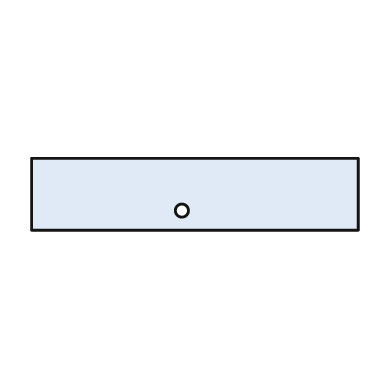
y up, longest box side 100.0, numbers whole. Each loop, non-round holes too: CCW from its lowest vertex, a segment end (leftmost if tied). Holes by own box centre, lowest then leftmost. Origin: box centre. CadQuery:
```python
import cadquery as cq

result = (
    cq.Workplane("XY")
    .moveTo(-50.0, -11.0)
    .lineTo(50.0, -11.0)
    .lineTo(50.0, 11.0)
    .lineTo(-50.0, 11.0)
    .close()
    .moveTo(-4.0, -5.0)
    .circle(2.0)
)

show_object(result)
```